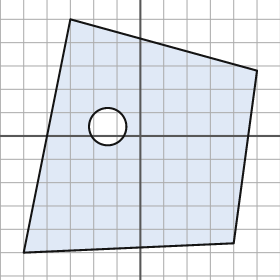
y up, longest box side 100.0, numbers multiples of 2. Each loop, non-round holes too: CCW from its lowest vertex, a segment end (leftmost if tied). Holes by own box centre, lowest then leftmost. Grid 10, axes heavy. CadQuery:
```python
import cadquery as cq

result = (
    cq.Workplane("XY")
    .moveTo(-50.0, -50.0)
    .lineTo(40.0, -46.0)
    .lineTo(50.0, 28.0)
    .lineTo(-30.0, 50.0)
    .close()
    .moveTo(-14.0, 4.0)
    .circle(8.0)
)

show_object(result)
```